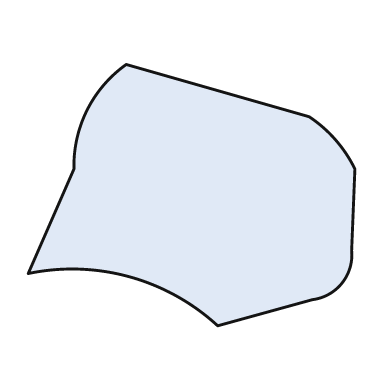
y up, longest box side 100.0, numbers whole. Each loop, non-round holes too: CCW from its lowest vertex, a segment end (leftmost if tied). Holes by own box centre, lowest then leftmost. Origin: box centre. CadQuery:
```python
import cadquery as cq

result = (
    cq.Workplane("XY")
    .moveTo(8.0, -40.0)
    .lineTo(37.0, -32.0)
    .threePointArc((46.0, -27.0), (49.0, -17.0))
    .lineTo(50.0, 8.0)
    .threePointArc((44.0, 17.0), (36.0, 24.0))
    .lineTo(-20.0, 40.0)
    .threePointArc((-32.0, 26.0), (-36.0, 8.0))
    .lineTo(-50.0, -24.0)
    .threePointArc((-19.0, -25.0), (8.0, -40.0))
    .close()
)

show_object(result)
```